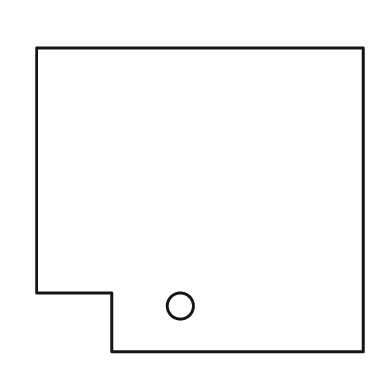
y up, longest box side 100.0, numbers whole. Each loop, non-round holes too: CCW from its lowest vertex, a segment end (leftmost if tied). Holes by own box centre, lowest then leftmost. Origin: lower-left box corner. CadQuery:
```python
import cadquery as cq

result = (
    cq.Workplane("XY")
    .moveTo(23.0, 0.0)
    .lineTo(100.0, 0.0)
    .lineTo(100.0, 93.0)
    .lineTo(0.0, 93.0)
    .lineTo(0.0, 18.0)
    .lineTo(23.0, 18.0)
    .close()
    .moveTo(44.0, 14.0)
    .circle(4.0)
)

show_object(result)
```